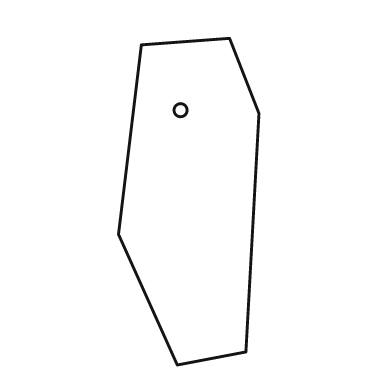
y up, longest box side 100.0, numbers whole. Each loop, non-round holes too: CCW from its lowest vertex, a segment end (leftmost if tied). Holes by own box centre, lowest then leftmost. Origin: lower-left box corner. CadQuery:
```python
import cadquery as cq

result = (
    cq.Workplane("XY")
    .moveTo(18.0, 0.0)
    .lineTo(39.0, 4.0)
    .lineTo(43.0, 77.0)
    .lineTo(34.0, 100.0)
    .lineTo(7.0, 98.0)
    .lineTo(0.0, 40.0)
    .close()
    .moveTo(19.0, 78.0)
    .circle(2.0)
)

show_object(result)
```